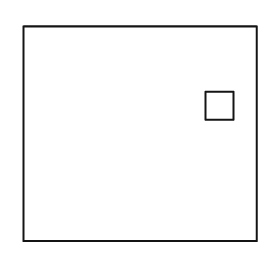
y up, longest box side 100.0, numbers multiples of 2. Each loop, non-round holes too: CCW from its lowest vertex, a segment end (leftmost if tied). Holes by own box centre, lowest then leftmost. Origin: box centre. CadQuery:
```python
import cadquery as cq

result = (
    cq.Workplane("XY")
    .moveTo(-50.0, -46.0)
    .lineTo(50.0, -46.0)
    .lineTo(50.0, 46.0)
    .lineTo(-50.0, 46.0)
    .close()
    .moveTo(28.0, 6.0)
    .lineTo(40.0, 6.0)
    .lineTo(40.0, 18.0)
    .lineTo(28.0, 18.0)
    .close()
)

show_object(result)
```